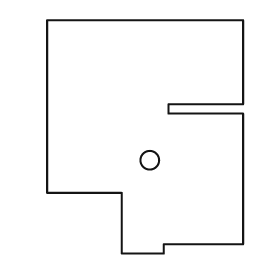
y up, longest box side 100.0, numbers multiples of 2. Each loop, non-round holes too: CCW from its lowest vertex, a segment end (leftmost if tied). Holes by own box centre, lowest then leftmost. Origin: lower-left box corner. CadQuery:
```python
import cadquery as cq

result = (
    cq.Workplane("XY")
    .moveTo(32.0, 0.0)
    .lineTo(50.0, 0.0)
    .lineTo(50.0, 4.0)
    .lineTo(84.0, 4.0)
    .lineTo(84.0, 60.0)
    .lineTo(52.0, 60.0)
    .lineTo(52.0, 64.0)
    .lineTo(84.0, 64.0)
    .lineTo(84.0, 100.0)
    .lineTo(0.0, 100.0)
    .lineTo(0.0, 26.0)
    .lineTo(32.0, 26.0)
    .close()
    .moveTo(44.0, 40.0)
    .circle(4.0)
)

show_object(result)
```